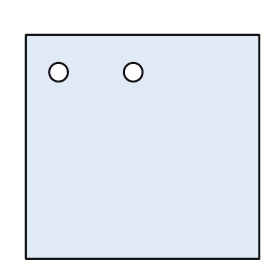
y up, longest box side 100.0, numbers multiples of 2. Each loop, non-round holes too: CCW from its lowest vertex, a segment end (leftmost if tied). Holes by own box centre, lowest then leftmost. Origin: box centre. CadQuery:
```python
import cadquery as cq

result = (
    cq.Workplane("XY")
    .moveTo(-50.0, -48.0)
    .lineTo(50.0, -48.0)
    .lineTo(50.0, 48.0)
    .lineTo(-50.0, 48.0)
    .close()
    .moveTo(-36.0, 32.0)
    .circle(4.0)
    .moveTo(-4.0, 32.0)
    .circle(4.0)
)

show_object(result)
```